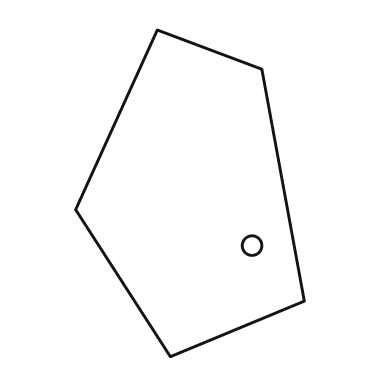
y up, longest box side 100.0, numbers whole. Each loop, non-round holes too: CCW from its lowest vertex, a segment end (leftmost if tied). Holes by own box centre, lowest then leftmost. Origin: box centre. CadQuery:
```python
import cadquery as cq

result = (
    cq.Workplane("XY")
    .moveTo(-6.0, -50.0)
    .lineTo(35.0, -33.0)
    .lineTo(22.0, 38.0)
    .lineTo(-10.0, 50.0)
    .lineTo(-35.0, -5.0)
    .close()
    .moveTo(19.0, -16.0)
    .circle(3.0)
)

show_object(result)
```